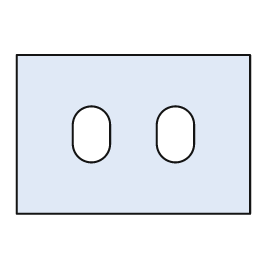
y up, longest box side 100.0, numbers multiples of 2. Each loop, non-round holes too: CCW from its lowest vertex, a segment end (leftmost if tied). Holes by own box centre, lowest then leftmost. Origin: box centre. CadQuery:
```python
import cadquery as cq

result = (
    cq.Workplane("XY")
    .moveTo(-50.0, -34.0)
    .lineTo(50.0, -34.0)
    .lineTo(50.0, 34.0)
    .lineTo(-50.0, 34.0)
    .close()
    .moveTo(-26.0, -4.0)
    .threePointArc((-18.0, -12.0), (-10.0, -4.0))
    .lineTo(-10.0, 4.0)
    .threePointArc((-18.0, 12.0), (-26.0, 4.0))
    .close()
    .moveTo(10.0, -4.0)
    .threePointArc((18.0, -12.0), (26.0, -4.0))
    .lineTo(26.0, 4.0)
    .threePointArc((18.0, 12.0), (10.0, 4.0))
    .close()
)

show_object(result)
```